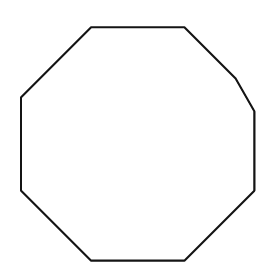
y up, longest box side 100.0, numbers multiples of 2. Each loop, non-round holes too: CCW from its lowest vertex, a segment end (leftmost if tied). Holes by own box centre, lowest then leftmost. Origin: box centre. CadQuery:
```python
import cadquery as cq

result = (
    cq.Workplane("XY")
    .moveTo(-20.0, -50.0)
    .lineTo(20.0, -50.0)
    .lineTo(50.0, -20.0)
    .lineTo(50.0, 14.0)
    .lineTo(42.0, 28.0)
    .lineTo(20.0, 50.0)
    .lineTo(-20.0, 50.0)
    .lineTo(-50.0, 20.0)
    .lineTo(-50.0, -20.0)
    .close()
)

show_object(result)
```